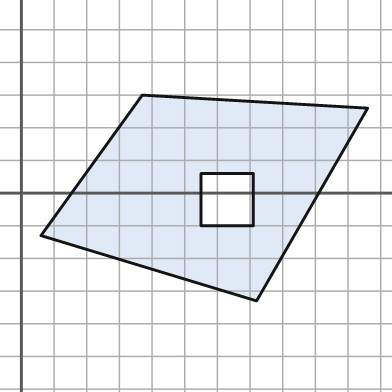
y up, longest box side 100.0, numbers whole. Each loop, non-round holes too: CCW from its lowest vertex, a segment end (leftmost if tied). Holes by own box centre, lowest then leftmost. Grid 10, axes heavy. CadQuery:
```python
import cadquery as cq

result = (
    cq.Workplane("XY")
    .moveTo(72.0, -33.0)
    .lineTo(106.0, 26.0)
    .lineTo(37.0, 30.0)
    .lineTo(6.0, -13.0)
    .close()
    .moveTo(55.0, -10.0)
    .lineTo(71.0, -10.0)
    .lineTo(71.0, 6.0)
    .lineTo(55.0, 6.0)
    .close()
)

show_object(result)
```